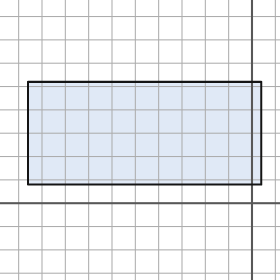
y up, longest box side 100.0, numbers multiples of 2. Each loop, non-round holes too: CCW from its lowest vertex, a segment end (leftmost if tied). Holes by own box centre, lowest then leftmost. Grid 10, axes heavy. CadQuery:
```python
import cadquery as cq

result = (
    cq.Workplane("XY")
    .moveTo(-96.0, 8.0)
    .lineTo(4.0, 8.0)
    .lineTo(4.0, 52.0)
    .lineTo(-96.0, 52.0)
    .close()
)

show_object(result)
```